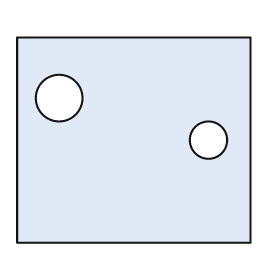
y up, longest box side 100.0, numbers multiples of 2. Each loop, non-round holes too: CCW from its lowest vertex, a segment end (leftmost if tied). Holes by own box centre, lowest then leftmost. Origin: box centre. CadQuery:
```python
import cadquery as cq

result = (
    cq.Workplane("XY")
    .moveTo(-50.0, -44.0)
    .lineTo(50.0, -44.0)
    .lineTo(50.0, 44.0)
    .lineTo(-50.0, 44.0)
    .close()
    .moveTo(32.0, 0.0)
    .circle(8.0)
    .moveTo(-32.0, 18.0)
    .circle(10.0)
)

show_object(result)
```